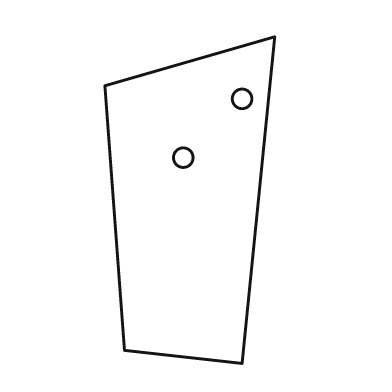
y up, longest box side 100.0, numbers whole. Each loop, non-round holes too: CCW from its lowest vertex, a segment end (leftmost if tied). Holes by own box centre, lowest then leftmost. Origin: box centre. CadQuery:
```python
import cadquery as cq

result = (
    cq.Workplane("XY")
    .moveTo(16.0, -50.0)
    .lineTo(26.0, 50.0)
    .lineTo(-26.0, 35.0)
    .lineTo(-20.0, -46.0)
    .close()
    .moveTo(-2.0, 13.0)
    .circle(3.0)
    .moveTo(16.0, 31.0)
    .circle(3.0)
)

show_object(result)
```